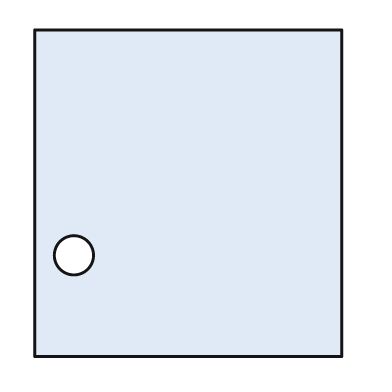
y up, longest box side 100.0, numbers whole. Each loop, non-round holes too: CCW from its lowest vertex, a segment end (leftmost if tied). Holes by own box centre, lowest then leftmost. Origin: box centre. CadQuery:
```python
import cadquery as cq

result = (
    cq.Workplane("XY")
    .moveTo(-47.0, -50.0)
    .lineTo(47.0, -50.0)
    .lineTo(47.0, 50.0)
    .lineTo(-47.0, 50.0)
    .close()
    .moveTo(-35.0, -19.0)
    .circle(6.0)
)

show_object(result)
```